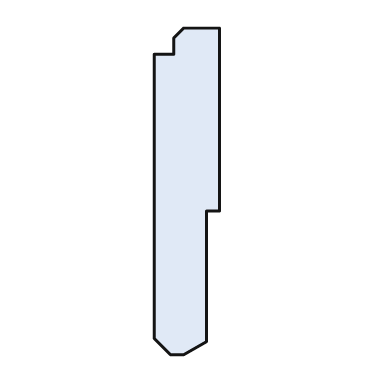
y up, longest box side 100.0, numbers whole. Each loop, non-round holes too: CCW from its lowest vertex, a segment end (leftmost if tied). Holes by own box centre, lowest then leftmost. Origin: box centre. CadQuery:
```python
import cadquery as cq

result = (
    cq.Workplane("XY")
    .moveTo(-5.0, -50.0)
    .lineTo(-1.0, -50.0)
    .lineTo(6.0, -46.0)
    .lineTo(6.0, -6.0)
    .lineTo(10.0, -6.0)
    .lineTo(10.0, 50.0)
    .lineTo(-1.0, 50.0)
    .lineTo(-4.0, 47.0)
    .lineTo(-4.0, 42.0)
    .lineTo(-10.0, 42.0)
    .lineTo(-10.0, -45.0)
    .close()
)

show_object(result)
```